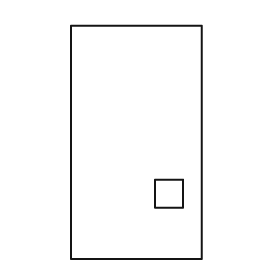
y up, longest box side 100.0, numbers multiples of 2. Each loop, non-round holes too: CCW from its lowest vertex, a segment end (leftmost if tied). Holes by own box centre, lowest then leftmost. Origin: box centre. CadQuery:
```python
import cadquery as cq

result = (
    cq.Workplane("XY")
    .moveTo(-28.0, -50.0)
    .lineTo(28.0, -50.0)
    .lineTo(28.0, 50.0)
    .lineTo(-28.0, 50.0)
    .close()
    .moveTo(8.0, -28.0)
    .lineTo(20.0, -28.0)
    .lineTo(20.0, -16.0)
    .lineTo(8.0, -16.0)
    .close()
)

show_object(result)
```